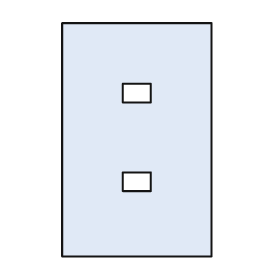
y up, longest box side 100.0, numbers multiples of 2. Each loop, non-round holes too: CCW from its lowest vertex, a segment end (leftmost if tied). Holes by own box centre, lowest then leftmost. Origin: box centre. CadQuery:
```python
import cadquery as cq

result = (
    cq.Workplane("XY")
    .moveTo(-32.0, -50.0)
    .lineTo(32.0, -50.0)
    .lineTo(32.0, 50.0)
    .lineTo(-32.0, 50.0)
    .close()
    .moveTo(-6.0, -22.0)
    .lineTo(6.0, -22.0)
    .lineTo(6.0, -14.0)
    .lineTo(-6.0, -14.0)
    .close()
    .moveTo(-6.0, 16.0)
    .lineTo(6.0, 16.0)
    .lineTo(6.0, 24.0)
    .lineTo(-6.0, 24.0)
    .close()
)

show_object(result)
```